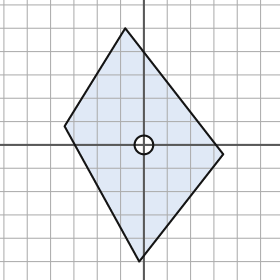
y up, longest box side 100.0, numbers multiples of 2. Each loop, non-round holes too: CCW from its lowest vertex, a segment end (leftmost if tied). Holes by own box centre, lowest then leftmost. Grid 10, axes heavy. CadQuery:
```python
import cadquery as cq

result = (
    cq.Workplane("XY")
    .moveTo(-2.0, -50.0)
    .lineTo(34.0, -4.0)
    .lineTo(-8.0, 50.0)
    .lineTo(-34.0, 8.0)
    .close()
    .moveTo(0.0, 0.0)
    .circle(4.0)
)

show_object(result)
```